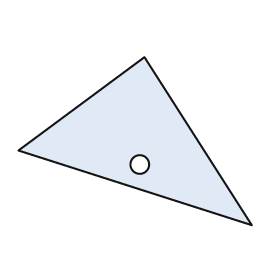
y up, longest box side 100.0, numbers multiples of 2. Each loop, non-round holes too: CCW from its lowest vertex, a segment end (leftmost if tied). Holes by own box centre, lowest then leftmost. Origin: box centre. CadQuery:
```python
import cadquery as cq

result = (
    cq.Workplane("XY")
    .moveTo(50.0, -36.0)
    .lineTo(4.0, 36.0)
    .lineTo(-50.0, -4.0)
    .close()
    .moveTo(2.0, -10.0)
    .circle(4.0)
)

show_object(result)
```